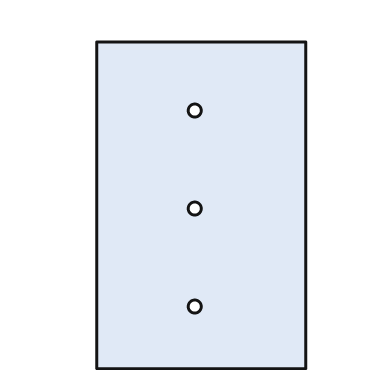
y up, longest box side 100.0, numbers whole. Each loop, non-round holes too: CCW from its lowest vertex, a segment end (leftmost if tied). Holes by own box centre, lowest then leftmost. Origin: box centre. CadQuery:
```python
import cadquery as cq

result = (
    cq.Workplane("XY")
    .moveTo(-32.0, -50.0)
    .lineTo(32.0, -50.0)
    .lineTo(32.0, 50.0)
    .lineTo(-32.0, 50.0)
    .close()
    .moveTo(-2.0, -31.0)
    .circle(2.0)
    .moveTo(-2.0, -1.0)
    .circle(2.0)
    .moveTo(-2.0, 29.0)
    .circle(2.0)
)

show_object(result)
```